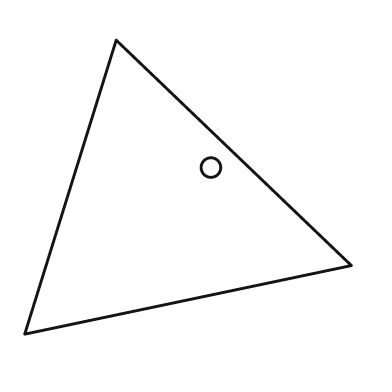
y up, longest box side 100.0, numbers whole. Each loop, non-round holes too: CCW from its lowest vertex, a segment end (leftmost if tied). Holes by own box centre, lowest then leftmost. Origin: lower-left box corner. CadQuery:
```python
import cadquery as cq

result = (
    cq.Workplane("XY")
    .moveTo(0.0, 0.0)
    .lineTo(100.0, 21.0)
    .lineTo(28.0, 90.0)
    .close()
    .moveTo(57.0, 51.0)
    .circle(3.0)
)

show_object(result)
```